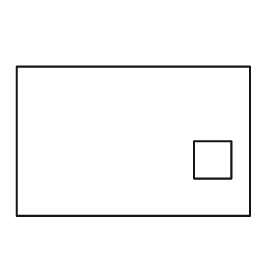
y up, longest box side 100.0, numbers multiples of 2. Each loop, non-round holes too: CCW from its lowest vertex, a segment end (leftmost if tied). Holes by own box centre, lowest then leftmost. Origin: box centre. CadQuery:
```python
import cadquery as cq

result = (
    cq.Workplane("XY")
    .moveTo(-50.0, -32.0)
    .lineTo(50.0, -32.0)
    .lineTo(50.0, 32.0)
    .lineTo(-50.0, 32.0)
    .close()
    .moveTo(26.0, -16.0)
    .lineTo(42.0, -16.0)
    .lineTo(42.0, 0.0)
    .lineTo(26.0, 0.0)
    .close()
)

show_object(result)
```